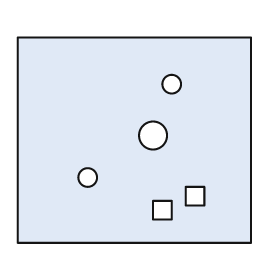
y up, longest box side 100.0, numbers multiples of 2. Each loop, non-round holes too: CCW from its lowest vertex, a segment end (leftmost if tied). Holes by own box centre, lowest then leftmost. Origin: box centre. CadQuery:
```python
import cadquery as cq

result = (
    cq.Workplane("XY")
    .moveTo(-50.0, -44.0)
    .lineTo(50.0, -44.0)
    .lineTo(50.0, 44.0)
    .lineTo(-50.0, 44.0)
    .close()
    .moveTo(8.0, -34.0)
    .lineTo(16.0, -34.0)
    .lineTo(16.0, -26.0)
    .lineTo(8.0, -26.0)
    .close()
    .moveTo(22.0, -28.0)
    .lineTo(30.0, -28.0)
    .lineTo(30.0, -20.0)
    .lineTo(22.0, -20.0)
    .close()
    .moveTo(-20.0, -16.0)
    .circle(4.0)
    .moveTo(8.0, 2.0)
    .circle(6.0)
    .moveTo(16.0, 24.0)
    .circle(4.0)
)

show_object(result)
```